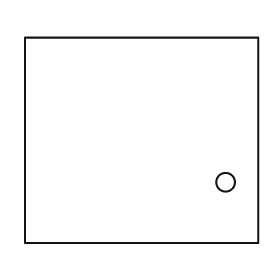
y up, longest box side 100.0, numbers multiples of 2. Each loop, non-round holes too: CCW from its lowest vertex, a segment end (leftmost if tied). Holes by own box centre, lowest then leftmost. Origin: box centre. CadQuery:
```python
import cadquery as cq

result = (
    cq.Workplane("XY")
    .moveTo(-50.0, -44.0)
    .lineTo(50.0, -44.0)
    .lineTo(50.0, 44.0)
    .lineTo(-50.0, 44.0)
    .close()
    .moveTo(36.0, -18.0)
    .circle(4.0)
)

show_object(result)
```